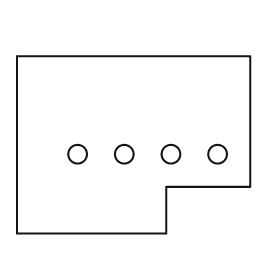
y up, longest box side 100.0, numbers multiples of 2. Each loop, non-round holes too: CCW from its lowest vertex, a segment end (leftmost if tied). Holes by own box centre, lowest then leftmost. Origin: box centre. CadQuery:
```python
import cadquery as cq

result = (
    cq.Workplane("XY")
    .moveTo(-50.0, -38.0)
    .lineTo(14.0, -38.0)
    .lineTo(14.0, -18.0)
    .lineTo(50.0, -18.0)
    .lineTo(50.0, 38.0)
    .lineTo(-50.0, 38.0)
    .close()
    .moveTo(-24.0, -4.0)
    .circle(4.0)
    .moveTo(-4.0, -4.0)
    .circle(4.0)
    .moveTo(16.0, -4.0)
    .circle(4.0)
    .moveTo(36.0, -4.0)
    .circle(4.0)
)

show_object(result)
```